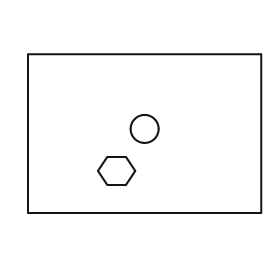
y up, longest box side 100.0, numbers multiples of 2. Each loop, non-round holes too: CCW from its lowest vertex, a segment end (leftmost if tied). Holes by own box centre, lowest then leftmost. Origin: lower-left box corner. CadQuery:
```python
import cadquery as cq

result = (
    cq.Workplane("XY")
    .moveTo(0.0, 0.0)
    .lineTo(100.0, 0.0)
    .lineTo(100.0, 68.0)
    .lineTo(0.0, 68.0)
    .close()
    .moveTo(34.0, 12.0)
    .lineTo(42.0, 12.0)
    .lineTo(46.0, 18.0)
    .lineTo(42.0, 24.0)
    .lineTo(34.0, 24.0)
    .lineTo(30.0, 18.0)
    .close()
    .moveTo(50.0, 36.0)
    .circle(6.0)
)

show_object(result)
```